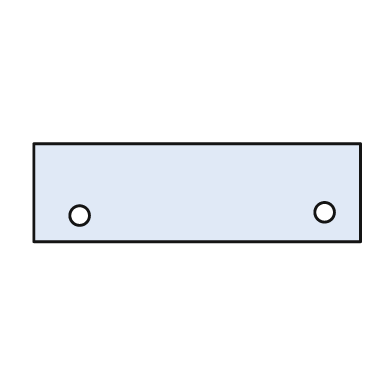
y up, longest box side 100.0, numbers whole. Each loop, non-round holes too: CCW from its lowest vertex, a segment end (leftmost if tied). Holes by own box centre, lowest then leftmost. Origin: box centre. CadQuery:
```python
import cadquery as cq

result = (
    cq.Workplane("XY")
    .moveTo(-50.0, -15.0)
    .lineTo(50.0, -15.0)
    .lineTo(50.0, 15.0)
    .lineTo(-50.0, 15.0)
    .close()
    .moveTo(-36.0, -7.0)
    .circle(3.0)
    .moveTo(39.0, -6.0)
    .circle(3.0)
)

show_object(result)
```